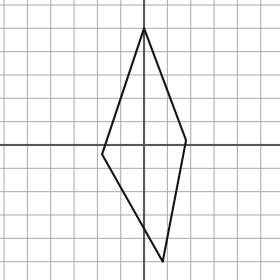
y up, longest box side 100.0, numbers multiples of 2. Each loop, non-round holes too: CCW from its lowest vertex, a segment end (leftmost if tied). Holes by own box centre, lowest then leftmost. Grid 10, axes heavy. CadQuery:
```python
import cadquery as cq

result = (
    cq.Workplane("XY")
    .moveTo(8.0, -50.0)
    .lineTo(18.0, 2.0)
    .lineTo(0.0, 50.0)
    .lineTo(-18.0, -4.0)
    .close()
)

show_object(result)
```